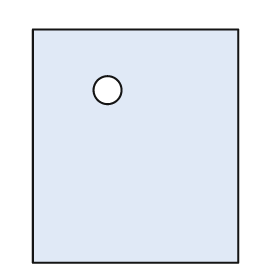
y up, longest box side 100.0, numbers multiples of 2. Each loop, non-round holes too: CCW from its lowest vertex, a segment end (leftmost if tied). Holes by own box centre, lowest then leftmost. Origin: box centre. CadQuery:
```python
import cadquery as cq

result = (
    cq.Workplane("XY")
    .moveTo(-44.0, -50.0)
    .lineTo(44.0, -50.0)
    .lineTo(44.0, 50.0)
    .lineTo(-44.0, 50.0)
    .close()
    .moveTo(-12.0, 24.0)
    .circle(6.0)
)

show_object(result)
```